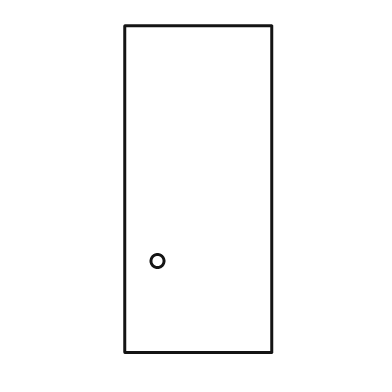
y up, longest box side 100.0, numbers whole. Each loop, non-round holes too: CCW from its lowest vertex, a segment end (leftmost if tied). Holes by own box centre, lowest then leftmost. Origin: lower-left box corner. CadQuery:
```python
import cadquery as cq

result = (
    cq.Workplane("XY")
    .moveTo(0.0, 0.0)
    .lineTo(45.0, 0.0)
    .lineTo(45.0, 100.0)
    .lineTo(0.0, 100.0)
    .close()
    .moveTo(10.0, 28.0)
    .circle(2.0)
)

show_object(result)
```